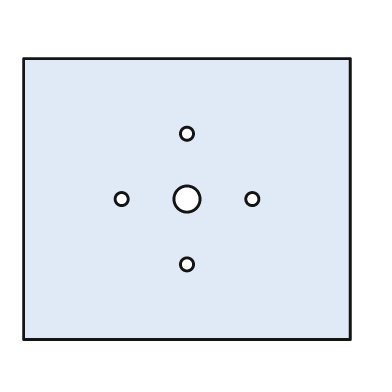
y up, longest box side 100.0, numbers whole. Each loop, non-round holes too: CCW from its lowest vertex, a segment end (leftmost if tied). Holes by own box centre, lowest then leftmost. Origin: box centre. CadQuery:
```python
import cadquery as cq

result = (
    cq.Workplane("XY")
    .moveTo(-50.0, -43.0)
    .lineTo(50.0, -43.0)
    .lineTo(50.0, 43.0)
    .lineTo(-50.0, 43.0)
    .close()
    .moveTo(0.0, -20.0)
    .circle(2.0)
    .moveTo(-20.0, 0.0)
    .circle(2.0)
    .moveTo(0.0, 0.0)
    .circle(4.0)
    .moveTo(20.0, 0.0)
    .circle(2.0)
    .moveTo(0.0, 20.0)
    .circle(2.0)
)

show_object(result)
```